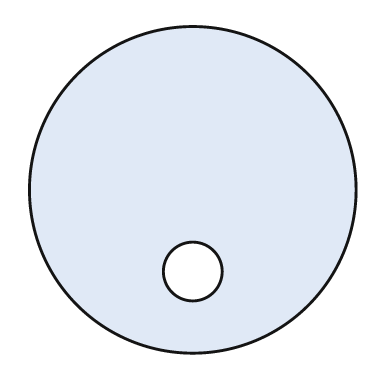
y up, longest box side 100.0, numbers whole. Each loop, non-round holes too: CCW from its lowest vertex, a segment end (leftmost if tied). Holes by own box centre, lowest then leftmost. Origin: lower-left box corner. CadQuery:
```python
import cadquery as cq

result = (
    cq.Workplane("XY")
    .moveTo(50.0, 50.0)
    .circle(50.0)
    .moveTo(50.0, 25.0)
    .circle(9.0)
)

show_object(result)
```